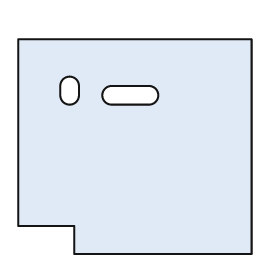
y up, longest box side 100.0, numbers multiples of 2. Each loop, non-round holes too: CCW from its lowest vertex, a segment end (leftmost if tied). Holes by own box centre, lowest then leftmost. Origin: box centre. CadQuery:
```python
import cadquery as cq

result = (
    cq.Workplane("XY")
    .moveTo(-26.0, -46.0)
    .lineTo(50.0, -46.0)
    .lineTo(50.0, 46.0)
    .lineTo(-50.0, 46.0)
    .lineTo(-50.0, -34.0)
    .lineTo(-26.0, -34.0)
    .close()
    .moveTo(-10.0, 18.0)
    .lineTo(6.0, 18.0)
    .threePointArc((10.0, 22.0), (6.0, 26.0))
    .lineTo(-10.0, 26.0)
    .threePointArc((-14.0, 22.0), (-10.0, 18.0))
    .close()
    .moveTo(-32.0, 22.0)
    .threePointArc((-28.0, 18.0), (-24.0, 22.0))
    .lineTo(-24.0, 26.0)
    .threePointArc((-28.0, 30.0), (-32.0, 26.0))
    .close()
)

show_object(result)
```